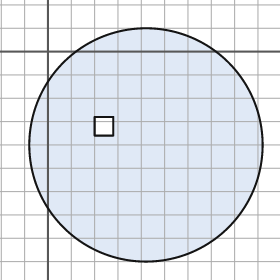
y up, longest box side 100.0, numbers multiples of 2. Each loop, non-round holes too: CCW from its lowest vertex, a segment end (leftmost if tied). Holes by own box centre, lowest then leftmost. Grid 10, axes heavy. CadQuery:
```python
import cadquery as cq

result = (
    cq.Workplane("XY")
    .moveTo(42.0, -40.0)
    .circle(50.0)
    .moveTo(20.0, -36.0)
    .lineTo(28.0, -36.0)
    .lineTo(28.0, -28.0)
    .lineTo(20.0, -28.0)
    .close()
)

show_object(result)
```